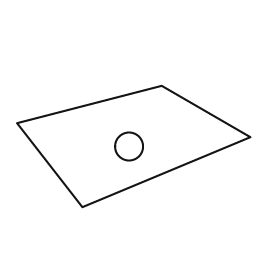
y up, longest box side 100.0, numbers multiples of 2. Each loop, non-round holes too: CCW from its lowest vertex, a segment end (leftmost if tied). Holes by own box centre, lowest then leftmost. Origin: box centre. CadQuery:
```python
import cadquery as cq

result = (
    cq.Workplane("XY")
    .moveTo(-22.0, -26.0)
    .lineTo(50.0, 4.0)
    .lineTo(12.0, 26.0)
    .lineTo(-50.0, 10.0)
    .close()
    .moveTo(-2.0, 0.0)
    .circle(6.0)
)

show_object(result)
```